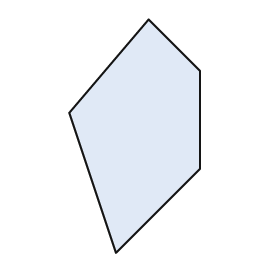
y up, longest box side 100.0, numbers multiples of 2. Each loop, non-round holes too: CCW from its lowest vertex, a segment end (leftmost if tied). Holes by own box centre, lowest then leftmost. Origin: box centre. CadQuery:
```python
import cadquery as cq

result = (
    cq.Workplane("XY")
    .moveTo(-8.0, -50.0)
    .lineTo(28.0, -14.0)
    .lineTo(28.0, 28.0)
    .lineTo(6.0, 50.0)
    .lineTo(-28.0, 10.0)
    .close()
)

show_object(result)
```